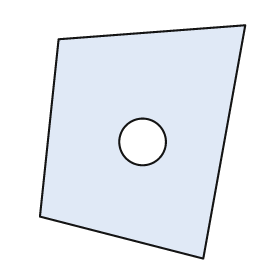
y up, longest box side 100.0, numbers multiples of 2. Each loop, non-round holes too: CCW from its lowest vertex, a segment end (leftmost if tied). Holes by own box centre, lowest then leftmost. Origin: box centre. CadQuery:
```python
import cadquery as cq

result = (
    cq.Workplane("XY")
    .moveTo(26.0, -50.0)
    .lineTo(44.0, 50.0)
    .lineTo(-36.0, 44.0)
    .lineTo(-44.0, -32.0)
    .close()
    .moveTo(0.0, 0.0)
    .circle(10.0)
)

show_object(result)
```